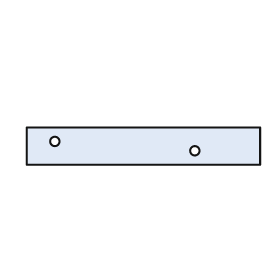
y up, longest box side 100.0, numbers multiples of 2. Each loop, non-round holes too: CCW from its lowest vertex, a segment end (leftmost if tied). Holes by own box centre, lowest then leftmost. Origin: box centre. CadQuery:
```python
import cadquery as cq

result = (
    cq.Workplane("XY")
    .moveTo(-50.0, -8.0)
    .lineTo(50.0, -8.0)
    .lineTo(50.0, 8.0)
    .lineTo(-50.0, 8.0)
    .close()
    .moveTo(22.0, -2.0)
    .circle(2.0)
    .moveTo(-38.0, 2.0)
    .circle(2.0)
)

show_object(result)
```